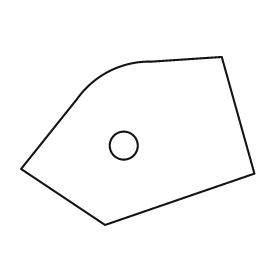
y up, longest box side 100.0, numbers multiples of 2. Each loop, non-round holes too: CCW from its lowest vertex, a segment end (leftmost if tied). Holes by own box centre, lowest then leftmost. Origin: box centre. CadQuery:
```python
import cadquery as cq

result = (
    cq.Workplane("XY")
    .moveTo(-14.0, -36.0)
    .lineTo(50.0, -14.0)
    .lineTo(36.0, 36.0)
    .lineTo(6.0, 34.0)
    .threePointArc((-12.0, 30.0), (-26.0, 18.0))
    .lineTo(-50.0, -12.0)
    .close()
    .moveTo(-6.0, -2.0)
    .circle(6.0)
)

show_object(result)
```